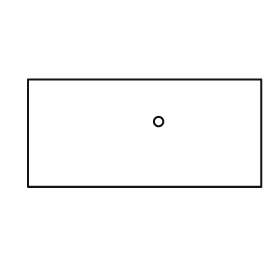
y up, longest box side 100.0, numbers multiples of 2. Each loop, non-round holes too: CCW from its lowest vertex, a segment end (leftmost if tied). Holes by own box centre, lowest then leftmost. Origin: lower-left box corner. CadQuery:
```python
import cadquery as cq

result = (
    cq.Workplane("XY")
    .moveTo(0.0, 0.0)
    .lineTo(100.0, 0.0)
    .lineTo(100.0, 46.0)
    .lineTo(0.0, 46.0)
    .close()
    .moveTo(56.0, 28.0)
    .circle(2.0)
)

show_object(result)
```